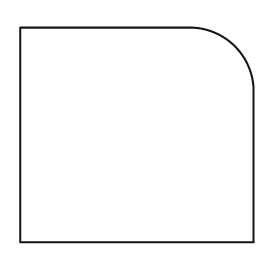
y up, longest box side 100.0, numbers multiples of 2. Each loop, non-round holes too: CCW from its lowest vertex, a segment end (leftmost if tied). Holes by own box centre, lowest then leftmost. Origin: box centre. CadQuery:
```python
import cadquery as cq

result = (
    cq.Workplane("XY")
    .moveTo(-50.0, -46.0)
    .lineTo(50.0, -46.0)
    .lineTo(50.0, 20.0)
    .threePointArc((42.0, 38.0), (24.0, 46.0))
    .lineTo(-50.0, 46.0)
    .close()
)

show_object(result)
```